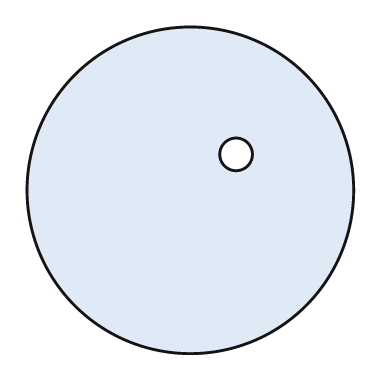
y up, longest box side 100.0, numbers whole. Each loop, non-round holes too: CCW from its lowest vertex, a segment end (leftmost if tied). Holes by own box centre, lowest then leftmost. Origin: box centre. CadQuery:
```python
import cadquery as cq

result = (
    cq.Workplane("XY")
    .moveTo(0.0, 0.0)
    .circle(50.0)
    .moveTo(14.0, 11.0)
    .circle(5.0)
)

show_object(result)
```